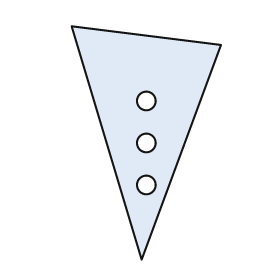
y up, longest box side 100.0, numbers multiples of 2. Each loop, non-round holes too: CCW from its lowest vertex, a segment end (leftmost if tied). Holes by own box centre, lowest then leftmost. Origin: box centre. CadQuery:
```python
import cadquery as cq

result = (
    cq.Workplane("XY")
    .moveTo(-2.0, -50.0)
    .lineTo(32.0, 42.0)
    .lineTo(-32.0, 50.0)
    .close()
    .moveTo(0.0, -18.0)
    .circle(4.0)
    .moveTo(0.0, 0.0)
    .circle(4.0)
    .moveTo(0.0, 18.0)
    .circle(4.0)
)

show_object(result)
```